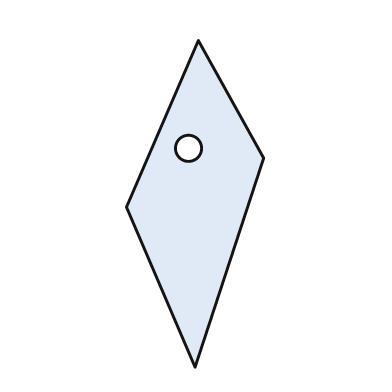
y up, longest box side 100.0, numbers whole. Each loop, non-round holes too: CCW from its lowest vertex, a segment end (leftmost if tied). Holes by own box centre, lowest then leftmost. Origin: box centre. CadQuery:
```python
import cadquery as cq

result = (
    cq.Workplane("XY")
    .moveTo(0.0, -50.0)
    .lineTo(21.0, 14.0)
    .lineTo(1.0, 50.0)
    .lineTo(-21.0, -1.0)
    .close()
    .moveTo(-2.0, 17.0)
    .circle(4.0)
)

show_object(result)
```